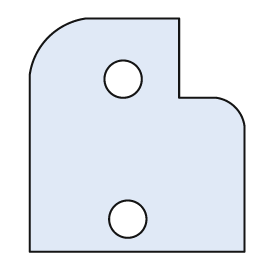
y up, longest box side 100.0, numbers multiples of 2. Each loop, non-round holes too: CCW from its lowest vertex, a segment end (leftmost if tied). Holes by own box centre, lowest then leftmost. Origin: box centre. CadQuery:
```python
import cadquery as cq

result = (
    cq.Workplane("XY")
    .moveTo(-46.0, -50.0)
    .lineTo(46.0, -50.0)
    .lineTo(46.0, 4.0)
    .threePointArc((42.0, 12.0), (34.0, 16.0))
    .lineTo(18.0, 16.0)
    .lineTo(18.0, 50.0)
    .lineTo(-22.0, 50.0)
    .threePointArc((-38.0, 42.0), (-46.0, 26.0))
    .close()
    .moveTo(-4.0, -36.0)
    .circle(8.0)
    .moveTo(-6.0, 24.0)
    .circle(8.0)
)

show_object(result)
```